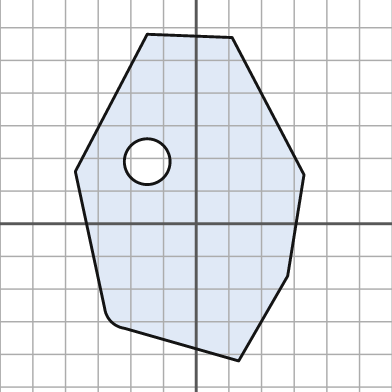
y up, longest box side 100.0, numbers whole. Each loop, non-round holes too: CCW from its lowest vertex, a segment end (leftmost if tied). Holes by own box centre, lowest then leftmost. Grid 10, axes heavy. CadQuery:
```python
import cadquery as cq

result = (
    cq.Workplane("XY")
    .moveTo(13.0, -42.0)
    .lineTo(28.0, -16.0)
    .lineTo(33.0, 15.0)
    .lineTo(11.0, 57.0)
    .lineTo(-15.0, 58.0)
    .lineTo(-37.0, 16.0)
    .lineTo(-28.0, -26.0)
    .threePointArc((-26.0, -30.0), (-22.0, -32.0))
    .close()
    .moveTo(-15.0, 19.0)
    .circle(7.0)
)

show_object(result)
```